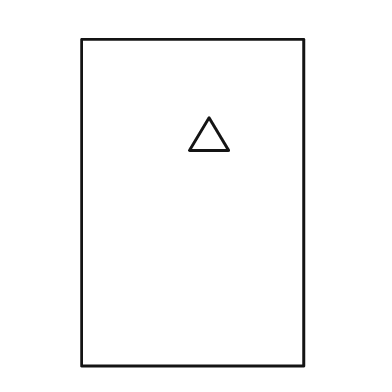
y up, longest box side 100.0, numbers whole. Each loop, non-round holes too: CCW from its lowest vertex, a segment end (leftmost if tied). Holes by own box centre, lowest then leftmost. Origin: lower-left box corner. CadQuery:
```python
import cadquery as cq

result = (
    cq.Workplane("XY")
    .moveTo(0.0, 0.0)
    .lineTo(68.0, 0.0)
    .lineTo(68.0, 100.0)
    .lineTo(0.0, 100.0)
    .close()
    .moveTo(33.0, 66.0)
    .lineTo(45.0, 66.0)
    .lineTo(39.0, 76.0)
    .close()
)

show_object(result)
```